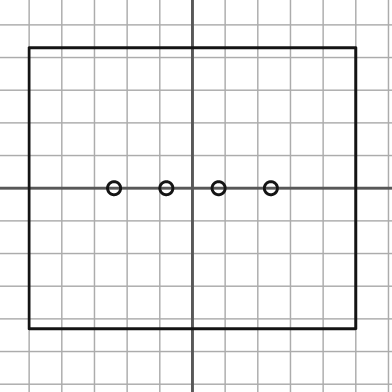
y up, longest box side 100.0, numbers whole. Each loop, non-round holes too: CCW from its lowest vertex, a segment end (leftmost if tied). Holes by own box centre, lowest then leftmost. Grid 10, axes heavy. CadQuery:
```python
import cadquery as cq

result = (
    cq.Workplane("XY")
    .moveTo(-50.0, -43.0)
    .lineTo(50.0, -43.0)
    .lineTo(50.0, 43.0)
    .lineTo(-50.0, 43.0)
    .close()
    .moveTo(-24.0, 0.0)
    .circle(2.0)
    .moveTo(-8.0, 0.0)
    .circle(2.0)
    .moveTo(8.0, 0.0)
    .circle(2.0)
    .moveTo(24.0, 0.0)
    .circle(2.0)
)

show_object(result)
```